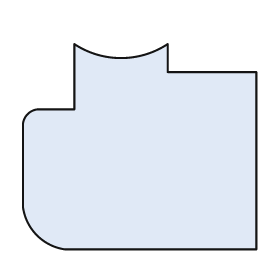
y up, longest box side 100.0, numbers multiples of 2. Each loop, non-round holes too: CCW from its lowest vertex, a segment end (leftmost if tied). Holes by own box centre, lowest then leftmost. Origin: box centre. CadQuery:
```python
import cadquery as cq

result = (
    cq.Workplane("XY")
    .moveTo(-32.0, -44.0)
    .lineTo(50.0, -44.0)
    .lineTo(50.0, 32.0)
    .lineTo(12.0, 32.0)
    .lineTo(12.0, 44.0)
    .threePointArc((-8.0, 38.0), (-28.0, 44.0))
    .lineTo(-28.0, 16.0)
    .lineTo(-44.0, 16.0)
    .threePointArc((-48.0, 14.0), (-50.0, 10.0))
    .lineTo(-50.0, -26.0)
    .threePointArc((-44.0, -38.0), (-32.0, -44.0))
    .close()
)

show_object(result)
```